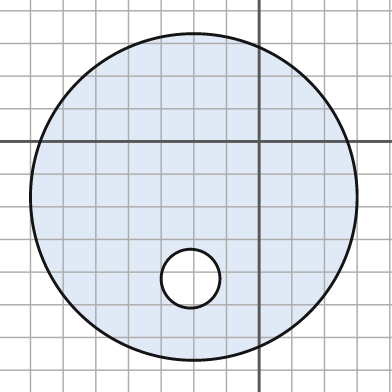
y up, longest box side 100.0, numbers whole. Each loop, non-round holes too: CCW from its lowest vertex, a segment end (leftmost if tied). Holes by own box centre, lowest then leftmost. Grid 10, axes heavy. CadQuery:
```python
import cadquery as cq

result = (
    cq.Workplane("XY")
    .moveTo(-20.0, -17.0)
    .circle(50.0)
    .moveTo(-21.0, -42.0)
    .circle(9.0)
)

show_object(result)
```